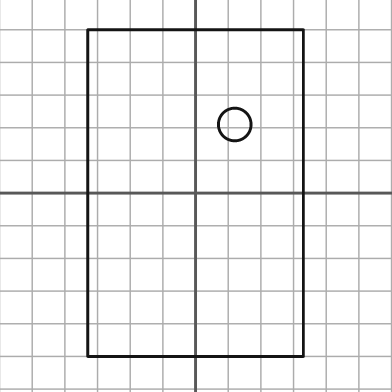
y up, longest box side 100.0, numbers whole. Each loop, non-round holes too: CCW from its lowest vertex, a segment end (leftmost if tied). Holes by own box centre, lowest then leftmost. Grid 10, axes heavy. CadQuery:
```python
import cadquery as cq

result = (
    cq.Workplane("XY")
    .moveTo(-33.0, -50.0)
    .lineTo(33.0, -50.0)
    .lineTo(33.0, 50.0)
    .lineTo(-33.0, 50.0)
    .close()
    .moveTo(12.0, 21.0)
    .circle(5.0)
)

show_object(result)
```